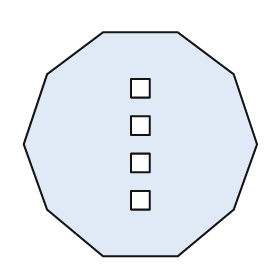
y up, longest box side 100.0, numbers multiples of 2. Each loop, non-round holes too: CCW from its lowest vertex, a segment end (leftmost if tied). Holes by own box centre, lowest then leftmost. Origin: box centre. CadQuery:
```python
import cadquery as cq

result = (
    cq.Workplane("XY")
    .moveTo(-16.0, -48.0)
    .lineTo(16.0, -48.0)
    .lineTo(40.0, -28.0)
    .lineTo(50.0, 0.0)
    .lineTo(40.0, 30.0)
    .lineTo(16.0, 48.0)
    .lineTo(-16.0, 48.0)
    .lineTo(-40.0, 30.0)
    .lineTo(-50.0, 0.0)
    .lineTo(-40.0, -28.0)
    .close()
    .moveTo(-4.0, -28.0)
    .lineTo(4.0, -28.0)
    .lineTo(4.0, -20.0)
    .lineTo(-4.0, -20.0)
    .close()
    .moveTo(-4.0, -12.0)
    .lineTo(4.0, -12.0)
    .lineTo(4.0, -4.0)
    .lineTo(-4.0, -4.0)
    .close()
    .moveTo(-4.0, 4.0)
    .lineTo(4.0, 4.0)
    .lineTo(4.0, 12.0)
    .lineTo(-4.0, 12.0)
    .close()
    .moveTo(-4.0, 20.0)
    .lineTo(4.0, 20.0)
    .lineTo(4.0, 28.0)
    .lineTo(-4.0, 28.0)
    .close()
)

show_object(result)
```